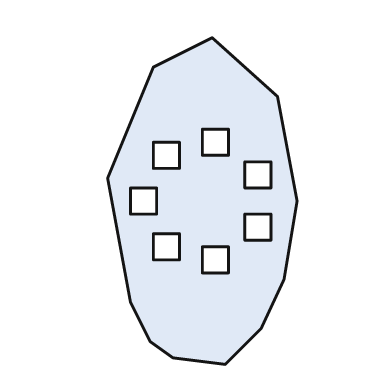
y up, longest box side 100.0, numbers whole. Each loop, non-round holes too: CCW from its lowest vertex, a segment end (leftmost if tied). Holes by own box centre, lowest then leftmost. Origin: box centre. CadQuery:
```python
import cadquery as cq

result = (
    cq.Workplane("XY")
    .moveTo(7.0, -50.0)
    .lineTo(18.0, -39.0)
    .lineTo(25.0, -24.0)
    .lineTo(29.0, 0.0)
    .lineTo(23.0, 32.0)
    .lineTo(3.0, 50.0)
    .lineTo(-15.0, 41.0)
    .lineTo(-29.0, 7.0)
    .lineTo(-22.0, -31.0)
    .lineTo(-16.0, -43.0)
    .lineTo(-9.0, -48.0)
    .close()
    .moveTo(0.0, -22.0)
    .lineTo(8.0, -22.0)
    .lineTo(8.0, -14.0)
    .lineTo(0.0, -14.0)
    .close()
    .moveTo(-15.0, -18.0)
    .lineTo(-7.0, -18.0)
    .lineTo(-7.0, -10.0)
    .lineTo(-15.0, -10.0)
    .close()
    .moveTo(13.0, -12.0)
    .lineTo(21.0, -12.0)
    .lineTo(21.0, -4.0)
    .lineTo(13.0, -4.0)
    .close()
    .moveTo(-22.0, -4.0)
    .lineTo(-14.0, -4.0)
    .lineTo(-14.0, 4.0)
    .lineTo(-22.0, 4.0)
    .close()
    .moveTo(13.0, 4.0)
    .lineTo(21.0, 4.0)
    .lineTo(21.0, 12.0)
    .lineTo(13.0, 12.0)
    .close()
    .moveTo(-15.0, 10.0)
    .lineTo(-7.0, 10.0)
    .lineTo(-7.0, 18.0)
    .lineTo(-15.0, 18.0)
    .close()
    .moveTo(0.0, 14.0)
    .lineTo(8.0, 14.0)
    .lineTo(8.0, 22.0)
    .lineTo(0.0, 22.0)
    .close()
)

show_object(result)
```